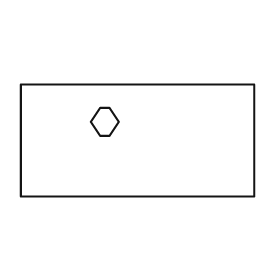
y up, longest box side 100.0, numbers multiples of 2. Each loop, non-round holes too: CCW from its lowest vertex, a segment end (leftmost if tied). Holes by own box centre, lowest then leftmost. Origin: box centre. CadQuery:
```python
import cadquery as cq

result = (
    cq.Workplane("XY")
    .moveTo(-50.0, -24.0)
    .lineTo(50.0, -24.0)
    .lineTo(50.0, 24.0)
    .lineTo(-50.0, 24.0)
    .close()
    .moveTo(-16.0, 2.0)
    .lineTo(-12.0, 2.0)
    .lineTo(-8.0, 8.0)
    .lineTo(-12.0, 14.0)
    .lineTo(-16.0, 14.0)
    .lineTo(-20.0, 8.0)
    .close()
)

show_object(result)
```